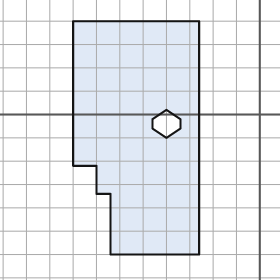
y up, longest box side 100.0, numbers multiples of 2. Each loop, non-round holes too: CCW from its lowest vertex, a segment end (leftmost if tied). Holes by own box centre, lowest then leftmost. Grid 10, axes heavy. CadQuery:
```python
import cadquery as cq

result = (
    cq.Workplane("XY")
    .moveTo(-64.0, -60.0)
    .lineTo(-26.0, -60.0)
    .lineTo(-26.0, 40.0)
    .lineTo(-80.0, 40.0)
    .lineTo(-80.0, -22.0)
    .lineTo(-70.0, -22.0)
    .lineTo(-70.0, -34.0)
    .lineTo(-64.0, -34.0)
    .close()
    .moveTo(-40.0, -10.0)
    .lineTo(-34.0, -6.0)
    .lineTo(-34.0, -2.0)
    .lineTo(-40.0, 2.0)
    .lineTo(-46.0, -2.0)
    .lineTo(-46.0, -6.0)
    .close()
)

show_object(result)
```